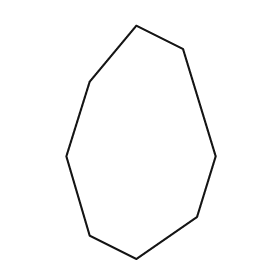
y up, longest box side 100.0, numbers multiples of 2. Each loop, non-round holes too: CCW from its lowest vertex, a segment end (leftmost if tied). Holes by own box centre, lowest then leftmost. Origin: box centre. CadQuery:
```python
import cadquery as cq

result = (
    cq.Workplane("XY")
    .moveTo(-2.0, -50.0)
    .lineTo(24.0, -32.0)
    .lineTo(32.0, -6.0)
    .lineTo(18.0, 40.0)
    .lineTo(-2.0, 50.0)
    .lineTo(-22.0, 26.0)
    .lineTo(-32.0, -6.0)
    .lineTo(-22.0, -40.0)
    .close()
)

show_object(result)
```